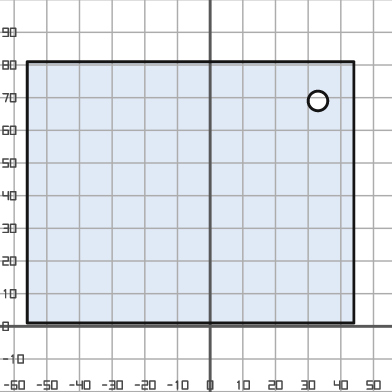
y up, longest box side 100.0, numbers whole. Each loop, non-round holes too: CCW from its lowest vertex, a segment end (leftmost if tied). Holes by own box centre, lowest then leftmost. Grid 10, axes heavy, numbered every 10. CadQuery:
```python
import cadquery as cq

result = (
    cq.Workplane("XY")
    .moveTo(-56.0, 1.0)
    .lineTo(44.0, 1.0)
    .lineTo(44.0, 81.0)
    .lineTo(-56.0, 81.0)
    .close()
    .moveTo(33.0, 69.0)
    .circle(3.0)
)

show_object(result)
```